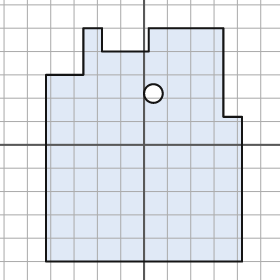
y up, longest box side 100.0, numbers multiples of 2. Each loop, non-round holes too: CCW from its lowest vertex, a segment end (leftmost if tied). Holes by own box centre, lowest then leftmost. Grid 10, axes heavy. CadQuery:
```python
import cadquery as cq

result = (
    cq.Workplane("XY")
    .moveTo(-42.0, -50.0)
    .lineTo(42.0, -50.0)
    .lineTo(42.0, 12.0)
    .lineTo(34.0, 12.0)
    .lineTo(34.0, 50.0)
    .lineTo(2.0, 50.0)
    .lineTo(2.0, 40.0)
    .lineTo(-18.0, 40.0)
    .lineTo(-18.0, 50.0)
    .lineTo(-26.0, 50.0)
    .lineTo(-26.0, 30.0)
    .lineTo(-42.0, 30.0)
    .close()
    .moveTo(4.0, 22.0)
    .circle(4.0)
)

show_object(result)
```